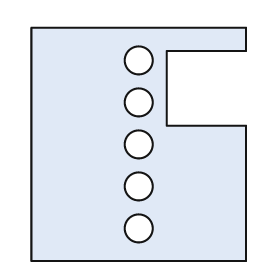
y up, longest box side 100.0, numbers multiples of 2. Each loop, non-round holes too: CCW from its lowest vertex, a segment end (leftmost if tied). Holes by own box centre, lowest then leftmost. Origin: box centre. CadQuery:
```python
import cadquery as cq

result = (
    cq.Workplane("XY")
    .moveTo(-46.0, -50.0)
    .lineTo(46.0, -50.0)
    .lineTo(46.0, 8.0)
    .lineTo(12.0, 8.0)
    .lineTo(12.0, 40.0)
    .lineTo(46.0, 40.0)
    .lineTo(46.0, 50.0)
    .lineTo(-46.0, 50.0)
    .close()
    .moveTo(0.0, -36.0)
    .circle(6.0)
    .moveTo(0.0, -18.0)
    .circle(6.0)
    .moveTo(0.0, 0.0)
    .circle(6.0)
    .moveTo(0.0, 18.0)
    .circle(6.0)
    .moveTo(0.0, 36.0)
    .circle(6.0)
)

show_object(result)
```